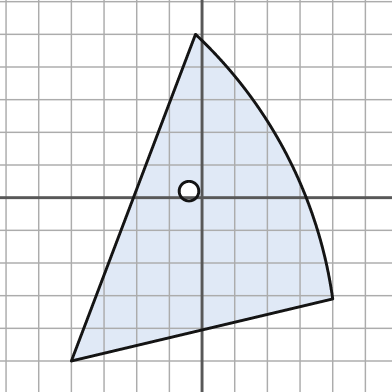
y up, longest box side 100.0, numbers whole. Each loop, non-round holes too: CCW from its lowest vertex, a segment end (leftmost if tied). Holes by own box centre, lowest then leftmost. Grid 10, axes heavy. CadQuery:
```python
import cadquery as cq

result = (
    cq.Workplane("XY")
    .moveTo(-40.0, -50.0)
    .lineTo(40.0, -31.0)
    .threePointArc((26.0, 13.0), (-2.0, 50.0))
    .close()
    .moveTo(-4.0, 2.0)
    .circle(3.0)
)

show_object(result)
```